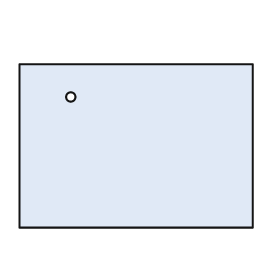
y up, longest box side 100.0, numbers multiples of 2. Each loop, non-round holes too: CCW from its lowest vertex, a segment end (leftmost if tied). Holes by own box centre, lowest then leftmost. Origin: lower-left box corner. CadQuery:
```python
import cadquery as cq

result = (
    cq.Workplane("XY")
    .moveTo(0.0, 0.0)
    .lineTo(100.0, 0.0)
    .lineTo(100.0, 70.0)
    .lineTo(0.0, 70.0)
    .close()
    .moveTo(22.0, 56.0)
    .circle(2.0)
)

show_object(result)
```